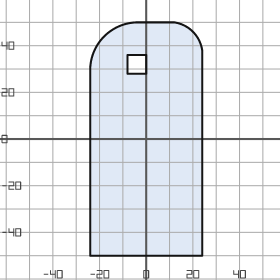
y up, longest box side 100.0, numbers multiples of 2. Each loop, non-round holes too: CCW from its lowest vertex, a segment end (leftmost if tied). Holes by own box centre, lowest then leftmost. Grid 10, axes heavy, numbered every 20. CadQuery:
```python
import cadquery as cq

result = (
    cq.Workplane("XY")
    .moveTo(-24.0, -50.0)
    .lineTo(24.0, -50.0)
    .lineTo(24.0, 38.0)
    .threePointArc((20.0, 46.0), (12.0, 50.0))
    .lineTo(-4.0, 50.0)
    .threePointArc((-18.0, 44.0), (-24.0, 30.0))
    .close()
    .moveTo(-8.0, 28.0)
    .lineTo(0.0, 28.0)
    .lineTo(0.0, 36.0)
    .lineTo(-8.0, 36.0)
    .close()
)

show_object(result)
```